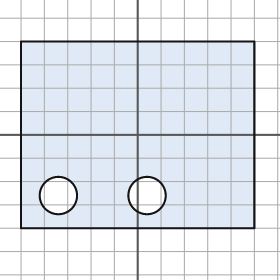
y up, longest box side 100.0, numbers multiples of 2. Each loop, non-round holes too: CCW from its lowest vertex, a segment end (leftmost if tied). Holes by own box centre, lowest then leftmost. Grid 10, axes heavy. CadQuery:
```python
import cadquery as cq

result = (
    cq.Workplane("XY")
    .moveTo(-50.0, -40.0)
    .lineTo(50.0, -40.0)
    .lineTo(50.0, 40.0)
    .lineTo(-50.0, 40.0)
    .close()
    .moveTo(-34.0, -26.0)
    .circle(8.0)
    .moveTo(4.0, -26.0)
    .circle(8.0)
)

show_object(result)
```